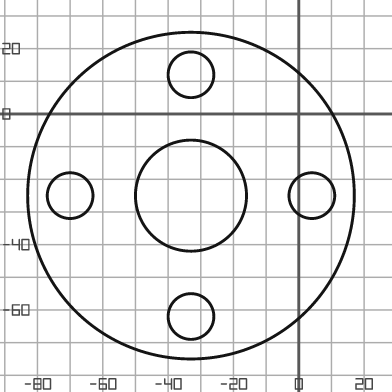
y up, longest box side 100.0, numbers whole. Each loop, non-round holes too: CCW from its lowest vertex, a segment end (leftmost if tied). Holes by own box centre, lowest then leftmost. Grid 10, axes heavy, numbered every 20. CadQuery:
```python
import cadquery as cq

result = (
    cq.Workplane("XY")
    .moveTo(-33.0, -25.0)
    .circle(50.0)
    .moveTo(-33.0, -62.0)
    .circle(7.0)
    .moveTo(-70.0, -25.0)
    .circle(7.0)
    .moveTo(-33.0, -25.0)
    .circle(17.0)
    .moveTo(4.0, -25.0)
    .circle(7.0)
    .moveTo(-33.0, 12.0)
    .circle(7.0)
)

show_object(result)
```